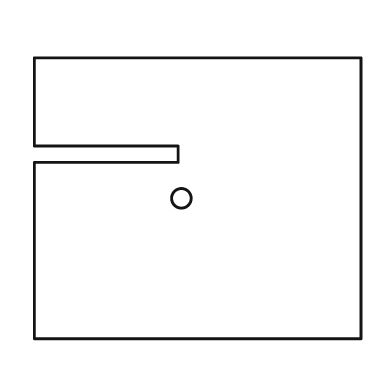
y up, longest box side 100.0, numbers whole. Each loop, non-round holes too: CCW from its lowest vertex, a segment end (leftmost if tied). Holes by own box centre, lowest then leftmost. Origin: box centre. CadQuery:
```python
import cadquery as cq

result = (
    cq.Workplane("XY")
    .moveTo(-50.0, -43.0)
    .lineTo(50.0, -43.0)
    .lineTo(50.0, 43.0)
    .lineTo(-50.0, 43.0)
    .lineTo(-50.0, 16.0)
    .lineTo(-6.0, 16.0)
    .lineTo(-6.0, 11.0)
    .lineTo(-50.0, 11.0)
    .close()
    .moveTo(-5.0, 0.0)
    .circle(3.0)
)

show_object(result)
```